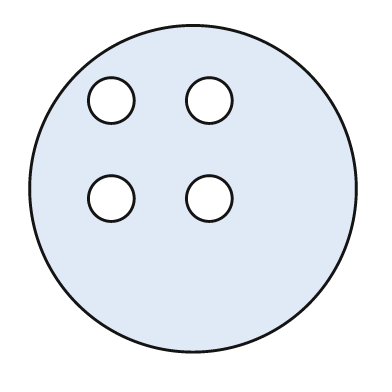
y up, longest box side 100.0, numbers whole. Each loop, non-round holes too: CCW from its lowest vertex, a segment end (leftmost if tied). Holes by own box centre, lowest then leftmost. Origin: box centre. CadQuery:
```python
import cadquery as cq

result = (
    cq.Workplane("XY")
    .moveTo(0.0, 0.0)
    .circle(50.0)
    .moveTo(-25.0, -3.0)
    .circle(7.0)
    .moveTo(5.0, -3.0)
    .circle(7.0)
    .moveTo(-25.0, 27.0)
    .circle(7.0)
    .moveTo(5.0, 27.0)
    .circle(7.0)
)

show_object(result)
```